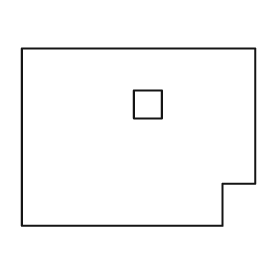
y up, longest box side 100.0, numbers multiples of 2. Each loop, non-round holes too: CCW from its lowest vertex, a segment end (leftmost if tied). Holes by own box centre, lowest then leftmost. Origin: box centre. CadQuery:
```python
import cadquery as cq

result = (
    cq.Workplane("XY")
    .moveTo(-50.0, -38.0)
    .lineTo(36.0, -38.0)
    .lineTo(36.0, -20.0)
    .lineTo(50.0, -20.0)
    .lineTo(50.0, 38.0)
    .lineTo(-50.0, 38.0)
    .close()
    .moveTo(-2.0, 8.0)
    .lineTo(10.0, 8.0)
    .lineTo(10.0, 20.0)
    .lineTo(-2.0, 20.0)
    .close()
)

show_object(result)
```